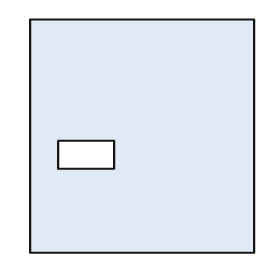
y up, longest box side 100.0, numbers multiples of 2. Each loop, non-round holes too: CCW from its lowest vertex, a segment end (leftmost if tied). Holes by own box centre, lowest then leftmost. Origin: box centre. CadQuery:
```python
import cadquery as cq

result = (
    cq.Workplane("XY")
    .moveTo(-48.0, -50.0)
    .lineTo(48.0, -50.0)
    .lineTo(48.0, 50.0)
    .lineTo(-48.0, 50.0)
    .close()
    .moveTo(-36.0, -14.0)
    .lineTo(-12.0, -14.0)
    .lineTo(-12.0, -2.0)
    .lineTo(-36.0, -2.0)
    .close()
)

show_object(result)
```